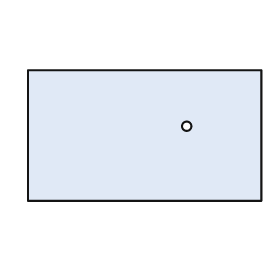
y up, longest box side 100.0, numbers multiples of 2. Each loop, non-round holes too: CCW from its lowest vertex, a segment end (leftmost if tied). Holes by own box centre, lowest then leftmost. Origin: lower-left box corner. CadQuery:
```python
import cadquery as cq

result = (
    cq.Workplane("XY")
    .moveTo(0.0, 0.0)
    .lineTo(100.0, 0.0)
    .lineTo(100.0, 56.0)
    .lineTo(0.0, 56.0)
    .close()
    .moveTo(68.0, 32.0)
    .circle(2.0)
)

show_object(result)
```